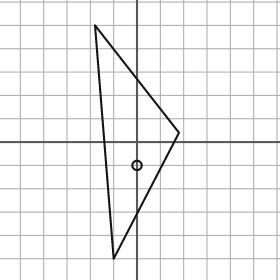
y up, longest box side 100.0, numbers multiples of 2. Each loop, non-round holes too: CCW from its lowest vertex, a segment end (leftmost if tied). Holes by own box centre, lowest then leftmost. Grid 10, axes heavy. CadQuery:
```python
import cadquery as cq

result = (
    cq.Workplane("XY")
    .moveTo(-10.0, -50.0)
    .lineTo(18.0, 4.0)
    .lineTo(-18.0, 50.0)
    .close()
    .moveTo(0.0, -10.0)
    .circle(2.0)
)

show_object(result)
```